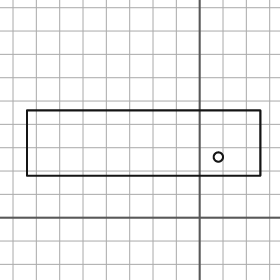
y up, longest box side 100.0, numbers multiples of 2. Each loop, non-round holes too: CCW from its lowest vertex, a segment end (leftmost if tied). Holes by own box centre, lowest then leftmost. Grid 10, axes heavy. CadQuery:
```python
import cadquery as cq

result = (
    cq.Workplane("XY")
    .moveTo(-74.0, 18.0)
    .lineTo(26.0, 18.0)
    .lineTo(26.0, 46.0)
    .lineTo(-74.0, 46.0)
    .close()
    .moveTo(8.0, 26.0)
    .circle(2.0)
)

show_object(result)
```